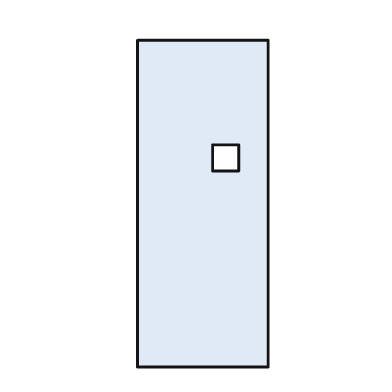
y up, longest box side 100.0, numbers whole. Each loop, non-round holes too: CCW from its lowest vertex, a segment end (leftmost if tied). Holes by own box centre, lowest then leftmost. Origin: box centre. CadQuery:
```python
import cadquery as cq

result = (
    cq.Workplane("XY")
    .moveTo(-20.0, -50.0)
    .lineTo(20.0, -50.0)
    .lineTo(20.0, 50.0)
    .lineTo(-20.0, 50.0)
    .close()
    .moveTo(3.0, 10.0)
    .lineTo(11.0, 10.0)
    .lineTo(11.0, 18.0)
    .lineTo(3.0, 18.0)
    .close()
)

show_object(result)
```